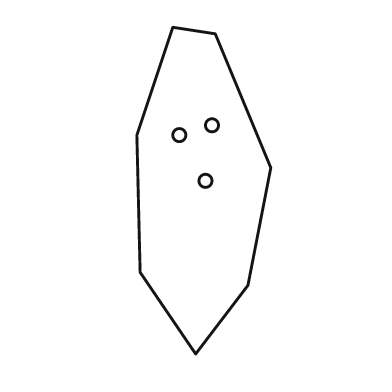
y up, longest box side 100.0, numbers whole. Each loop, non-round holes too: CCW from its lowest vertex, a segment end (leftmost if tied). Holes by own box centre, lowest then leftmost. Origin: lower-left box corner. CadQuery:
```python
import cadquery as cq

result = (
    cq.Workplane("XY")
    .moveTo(18.0, 0.0)
    .lineTo(34.0, 21.0)
    .lineTo(41.0, 57.0)
    .lineTo(24.0, 98.0)
    .lineTo(11.0, 100.0)
    .lineTo(0.0, 67.0)
    .lineTo(1.0, 25.0)
    .close()
    .moveTo(21.0, 53.0)
    .circle(2.0)
    .moveTo(13.0, 67.0)
    .circle(2.0)
    .moveTo(23.0, 70.0)
    .circle(2.0)
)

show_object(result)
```